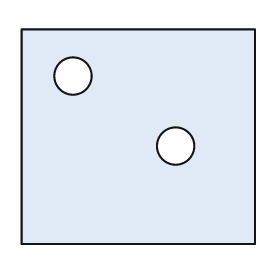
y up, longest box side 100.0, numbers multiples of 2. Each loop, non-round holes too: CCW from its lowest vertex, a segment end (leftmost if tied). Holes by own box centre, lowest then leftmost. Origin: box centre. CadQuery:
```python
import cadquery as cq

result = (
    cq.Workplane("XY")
    .moveTo(-50.0, -46.0)
    .lineTo(50.0, -46.0)
    .lineTo(50.0, 46.0)
    .lineTo(-50.0, 46.0)
    .close()
    .moveTo(16.0, -4.0)
    .circle(8.0)
    .moveTo(-28.0, 26.0)
    .circle(8.0)
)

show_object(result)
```